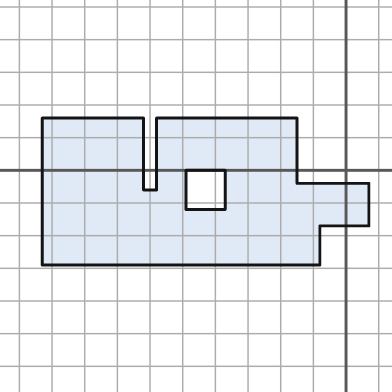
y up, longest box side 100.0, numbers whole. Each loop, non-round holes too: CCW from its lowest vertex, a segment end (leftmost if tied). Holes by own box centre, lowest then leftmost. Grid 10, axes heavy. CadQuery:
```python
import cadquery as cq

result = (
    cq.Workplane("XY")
    .moveTo(-93.0, -29.0)
    .lineTo(-8.0, -29.0)
    .lineTo(-8.0, -17.0)
    .lineTo(7.0, -17.0)
    .lineTo(7.0, -4.0)
    .lineTo(-15.0, -4.0)
    .lineTo(-15.0, 16.0)
    .lineTo(-58.0, 16.0)
    .lineTo(-58.0, -6.0)
    .lineTo(-62.0, -6.0)
    .lineTo(-62.0, 16.0)
    .lineTo(-93.0, 16.0)
    .close()
    .moveTo(-49.0, -12.0)
    .lineTo(-37.0, -12.0)
    .lineTo(-37.0, 0.0)
    .lineTo(-49.0, 0.0)
    .close()
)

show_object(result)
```